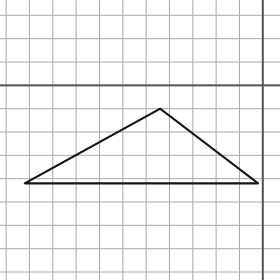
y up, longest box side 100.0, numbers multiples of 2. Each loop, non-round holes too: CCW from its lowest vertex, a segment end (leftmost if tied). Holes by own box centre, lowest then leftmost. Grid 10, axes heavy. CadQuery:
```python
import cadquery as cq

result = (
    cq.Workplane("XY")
    .moveTo(-102.0, -42.0)
    .lineTo(-2.0, -42.0)
    .lineTo(-44.0, -10.0)
    .close()
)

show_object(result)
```